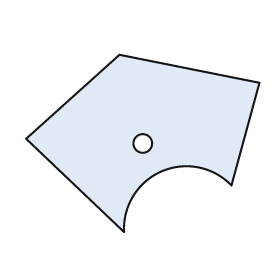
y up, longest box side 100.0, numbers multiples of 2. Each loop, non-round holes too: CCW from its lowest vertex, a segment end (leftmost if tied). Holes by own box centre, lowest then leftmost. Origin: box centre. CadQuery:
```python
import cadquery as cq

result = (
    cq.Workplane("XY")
    .moveTo(-8.0, -38.0)
    .threePointArc((8.0, -12.0), (38.0, -18.0))
    .lineTo(50.0, 26.0)
    .lineTo(-10.0, 38.0)
    .lineTo(-50.0, 2.0)
    .close()
    .moveTo(0.0, 0.0)
    .circle(4.0)
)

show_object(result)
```